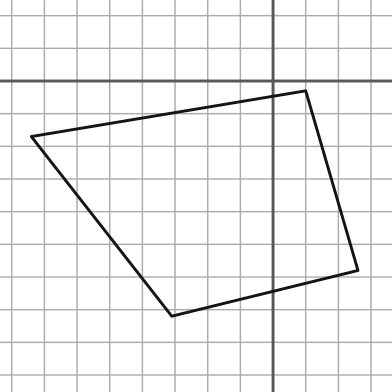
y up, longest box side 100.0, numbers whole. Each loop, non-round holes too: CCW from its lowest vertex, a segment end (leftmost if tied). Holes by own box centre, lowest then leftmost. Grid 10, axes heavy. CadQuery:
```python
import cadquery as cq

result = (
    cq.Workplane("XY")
    .moveTo(-31.0, -72.0)
    .lineTo(26.0, -58.0)
    .lineTo(10.0, -3.0)
    .lineTo(-74.0, -17.0)
    .close()
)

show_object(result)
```